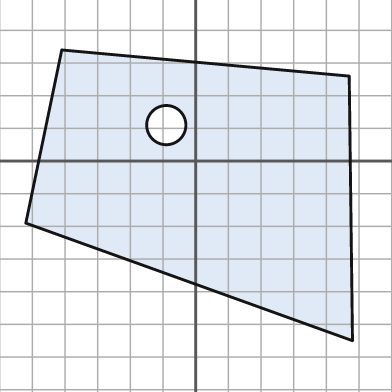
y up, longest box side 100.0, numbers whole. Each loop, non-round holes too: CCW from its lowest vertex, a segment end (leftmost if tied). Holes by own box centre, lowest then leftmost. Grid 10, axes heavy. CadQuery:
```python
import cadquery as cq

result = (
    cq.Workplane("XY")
    .moveTo(48.0, -55.0)
    .lineTo(47.0, 26.0)
    .lineTo(-41.0, 34.0)
    .lineTo(-52.0, -19.0)
    .close()
    .moveTo(-9.0, 11.0)
    .circle(6.0)
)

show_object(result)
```